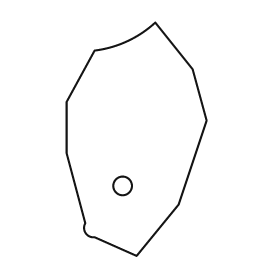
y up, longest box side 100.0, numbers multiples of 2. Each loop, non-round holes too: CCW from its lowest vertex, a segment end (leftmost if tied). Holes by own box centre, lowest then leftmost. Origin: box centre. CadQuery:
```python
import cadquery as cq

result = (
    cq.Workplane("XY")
    .moveTo(0.0, -50.0)
    .lineTo(18.0, -28.0)
    .lineTo(30.0, 8.0)
    .lineTo(24.0, 30.0)
    .lineTo(8.0, 50.0)
    .threePointArc((-4.0, 42.0), (-18.0, 38.0))
    .lineTo(-30.0, 16.0)
    .lineTo(-30.0, -6.0)
    .lineTo(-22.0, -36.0)
    .threePointArc((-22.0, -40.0), (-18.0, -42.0))
    .close()
    .moveTo(-6.0, -20.0)
    .circle(4.0)
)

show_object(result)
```